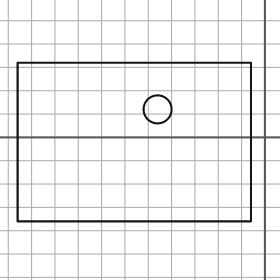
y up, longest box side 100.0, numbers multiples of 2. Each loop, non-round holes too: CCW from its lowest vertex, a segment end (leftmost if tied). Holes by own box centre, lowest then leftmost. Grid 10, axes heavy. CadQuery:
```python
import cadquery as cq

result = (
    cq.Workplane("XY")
    .moveTo(-106.0, -36.0)
    .lineTo(-6.0, -36.0)
    .lineTo(-6.0, 32.0)
    .lineTo(-106.0, 32.0)
    .close()
    .moveTo(-46.0, 12.0)
    .circle(6.0)
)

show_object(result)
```